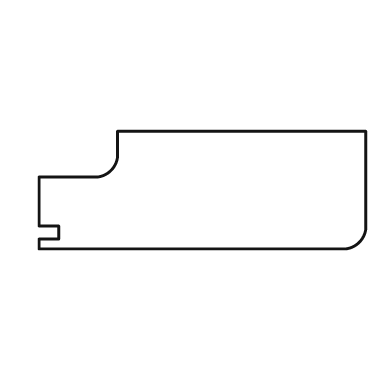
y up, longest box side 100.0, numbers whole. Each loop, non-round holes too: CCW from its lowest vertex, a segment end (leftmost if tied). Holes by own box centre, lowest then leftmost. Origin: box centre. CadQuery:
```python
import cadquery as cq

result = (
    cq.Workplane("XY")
    .moveTo(-50.0, -18.0)
    .lineTo(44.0, -18.0)
    .threePointArc((48.0, -16.0), (50.0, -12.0))
    .lineTo(50.0, 18.0)
    .lineTo(-26.0, 18.0)
    .lineTo(-26.0, 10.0)
    .threePointArc((-28.0, 6.0), (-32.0, 4.0))
    .lineTo(-50.0, 4.0)
    .lineTo(-50.0, -11.0)
    .lineTo(-44.0, -11.0)
    .lineTo(-44.0, -15.0)
    .lineTo(-50.0, -15.0)
    .close()
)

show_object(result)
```